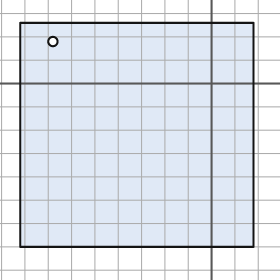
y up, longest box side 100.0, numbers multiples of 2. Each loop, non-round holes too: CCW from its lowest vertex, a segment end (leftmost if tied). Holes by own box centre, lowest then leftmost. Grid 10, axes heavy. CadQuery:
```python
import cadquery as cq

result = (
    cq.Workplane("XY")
    .moveTo(-82.0, -70.0)
    .lineTo(18.0, -70.0)
    .lineTo(18.0, 26.0)
    .lineTo(-82.0, 26.0)
    .close()
    .moveTo(-68.0, 18.0)
    .circle(2.0)
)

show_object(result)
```